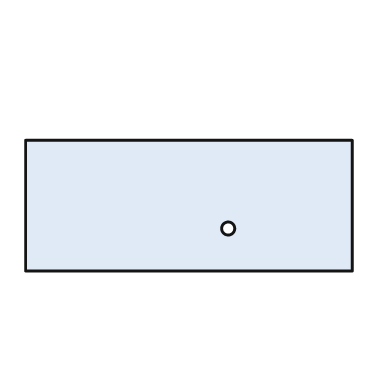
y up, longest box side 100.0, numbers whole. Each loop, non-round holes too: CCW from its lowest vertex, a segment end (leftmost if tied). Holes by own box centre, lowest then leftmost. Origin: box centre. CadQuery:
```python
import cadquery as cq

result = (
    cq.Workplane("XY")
    .moveTo(-50.0, -20.0)
    .lineTo(50.0, -20.0)
    .lineTo(50.0, 20.0)
    .lineTo(-50.0, 20.0)
    .close()
    .moveTo(12.0, -7.0)
    .circle(2.0)
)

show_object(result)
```